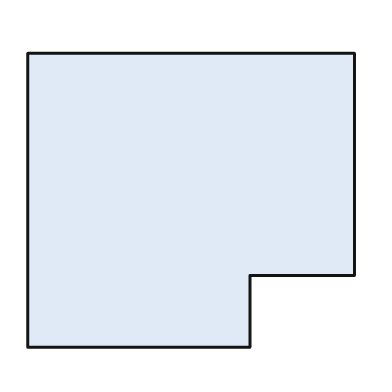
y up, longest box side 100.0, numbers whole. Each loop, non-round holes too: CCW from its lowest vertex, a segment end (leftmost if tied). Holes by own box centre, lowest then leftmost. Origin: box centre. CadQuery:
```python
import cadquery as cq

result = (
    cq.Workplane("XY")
    .moveTo(-50.0, -45.0)
    .lineTo(18.0, -45.0)
    .lineTo(18.0, -23.0)
    .lineTo(50.0, -23.0)
    .lineTo(50.0, 45.0)
    .lineTo(-50.0, 45.0)
    .close()
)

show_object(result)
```